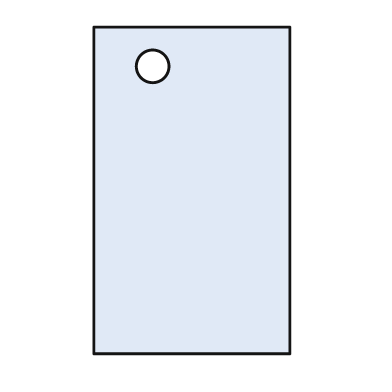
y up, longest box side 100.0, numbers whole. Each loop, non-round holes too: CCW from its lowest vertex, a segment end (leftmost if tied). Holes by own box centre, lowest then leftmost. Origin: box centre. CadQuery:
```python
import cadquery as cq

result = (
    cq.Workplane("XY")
    .moveTo(-30.0, -50.0)
    .lineTo(30.0, -50.0)
    .lineTo(30.0, 50.0)
    .lineTo(-30.0, 50.0)
    .close()
    .moveTo(-12.0, 38.0)
    .circle(5.0)
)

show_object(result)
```